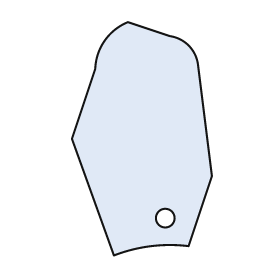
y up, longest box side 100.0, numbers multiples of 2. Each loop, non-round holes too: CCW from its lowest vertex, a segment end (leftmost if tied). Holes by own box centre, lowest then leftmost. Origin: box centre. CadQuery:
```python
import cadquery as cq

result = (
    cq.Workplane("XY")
    .moveTo(-12.0, -50.0)
    .threePointArc((4.0, -46.0), (20.0, -46.0))
    .lineTo(30.0, -16.0)
    .lineTo(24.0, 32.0)
    .threePointArc((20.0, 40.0), (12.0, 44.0))
    .lineTo(-6.0, 50.0)
    .threePointArc((-16.0, 42.0), (-20.0, 30.0))
    .lineTo(-30.0, 0.0)
    .close()
    .moveTo(10.0, -34.0)
    .circle(4.0)
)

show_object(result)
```